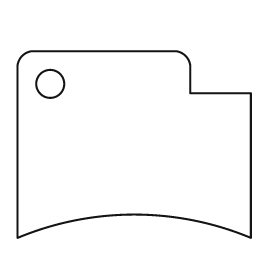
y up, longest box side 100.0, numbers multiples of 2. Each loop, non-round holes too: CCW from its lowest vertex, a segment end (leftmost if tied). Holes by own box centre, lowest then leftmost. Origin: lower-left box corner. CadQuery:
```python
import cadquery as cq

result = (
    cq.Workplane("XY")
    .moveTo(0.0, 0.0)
    .threePointArc((50.0, 10.0), (100.0, 0.0))
    .lineTo(100.0, 62.0)
    .lineTo(74.0, 62.0)
    .lineTo(74.0, 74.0)
    .threePointArc((72.0, 78.0), (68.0, 80.0))
    .lineTo(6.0, 80.0)
    .threePointArc((2.0, 78.0), (0.0, 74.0))
    .close()
    .moveTo(14.0, 66.0)
    .circle(6.0)
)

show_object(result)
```